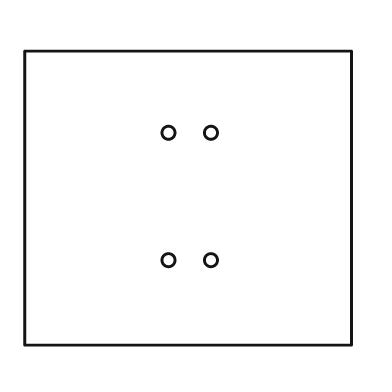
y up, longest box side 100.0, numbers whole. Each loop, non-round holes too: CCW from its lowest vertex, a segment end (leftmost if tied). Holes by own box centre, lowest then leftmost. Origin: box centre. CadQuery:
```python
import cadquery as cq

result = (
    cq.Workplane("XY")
    .moveTo(-50.0, -45.0)
    .lineTo(50.0, -45.0)
    .lineTo(50.0, 45.0)
    .lineTo(-50.0, 45.0)
    .close()
    .moveTo(-6.0, -19.0)
    .circle(2.0)
    .moveTo(7.0, -19.0)
    .circle(2.0)
    .moveTo(-6.0, 20.0)
    .circle(2.0)
    .moveTo(7.0, 20.0)
    .circle(2.0)
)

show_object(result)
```